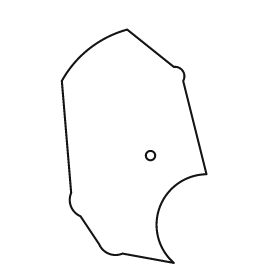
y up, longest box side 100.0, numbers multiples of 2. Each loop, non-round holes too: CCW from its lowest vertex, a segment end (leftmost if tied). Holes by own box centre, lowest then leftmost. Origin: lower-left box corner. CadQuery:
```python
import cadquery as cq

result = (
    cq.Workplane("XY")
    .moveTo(48.0, 0.0)
    .threePointArc((42.0, 24.0), (62.0, 38.0))
    .lineTo(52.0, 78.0)
    .threePointArc((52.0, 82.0), (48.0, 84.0))
    .lineTo(28.0, 100.0)
    .threePointArc((12.0, 92.0), (0.0, 78.0))
    .lineTo(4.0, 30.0)
    .threePointArc((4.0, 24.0), (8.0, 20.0))
    .lineTo(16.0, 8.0)
    .threePointArc((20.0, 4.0), (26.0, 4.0))
    .close()
    .moveTo(38.0, 46.0)
    .circle(2.0)
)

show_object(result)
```